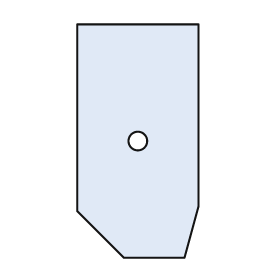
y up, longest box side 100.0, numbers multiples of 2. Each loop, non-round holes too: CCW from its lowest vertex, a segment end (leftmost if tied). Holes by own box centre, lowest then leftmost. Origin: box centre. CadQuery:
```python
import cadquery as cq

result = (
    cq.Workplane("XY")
    .moveTo(-6.0, -50.0)
    .lineTo(20.0, -50.0)
    .lineTo(26.0, -28.0)
    .lineTo(26.0, 50.0)
    .lineTo(-26.0, 50.0)
    .lineTo(-26.0, -30.0)
    .close()
    .moveTo(0.0, 0.0)
    .circle(4.0)
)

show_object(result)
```